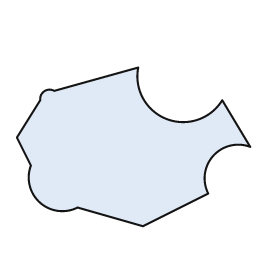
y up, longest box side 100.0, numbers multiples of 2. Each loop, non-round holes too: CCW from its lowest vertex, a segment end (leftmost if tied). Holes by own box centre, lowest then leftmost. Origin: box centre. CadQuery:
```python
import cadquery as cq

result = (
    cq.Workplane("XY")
    .moveTo(4.0, -34.0)
    .lineTo(32.0, -20.0)
    .threePointArc((34.0, -4.0), (50.0, 0.0))
    .lineTo(38.0, 20.0)
    .threePointArc((14.0, 12.0), (2.0, 34.0))
    .lineTo(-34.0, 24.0)
    .threePointArc((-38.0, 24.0), (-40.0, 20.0))
    .lineTo(-50.0, 4.0)
    .lineTo(-44.0, -8.0)
    .threePointArc((-40.0, -24.0), (-24.0, -26.0))
    .close()
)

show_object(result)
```